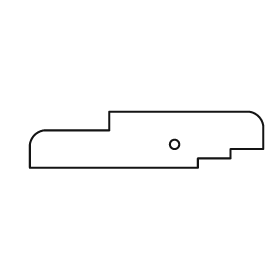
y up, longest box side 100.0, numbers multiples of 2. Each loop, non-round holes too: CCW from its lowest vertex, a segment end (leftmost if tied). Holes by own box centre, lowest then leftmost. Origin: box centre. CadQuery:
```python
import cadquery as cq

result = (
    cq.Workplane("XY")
    .moveTo(-50.0, -12.0)
    .lineTo(22.0, -12.0)
    .lineTo(22.0, -8.0)
    .lineTo(36.0, -8.0)
    .lineTo(36.0, -4.0)
    .lineTo(50.0, -4.0)
    .lineTo(50.0, 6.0)
    .threePointArc((48.0, 10.0), (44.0, 12.0))
    .lineTo(-16.0, 12.0)
    .lineTo(-16.0, 4.0)
    .lineTo(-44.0, 4.0)
    .threePointArc((-48.0, 2.0), (-50.0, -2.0))
    .close()
    .moveTo(12.0, -2.0)
    .circle(2.0)
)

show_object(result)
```